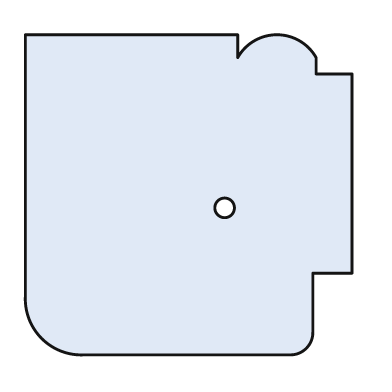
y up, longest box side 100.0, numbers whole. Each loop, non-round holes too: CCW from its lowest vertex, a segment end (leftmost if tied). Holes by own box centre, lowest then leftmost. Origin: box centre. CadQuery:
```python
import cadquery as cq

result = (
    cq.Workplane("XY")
    .moveTo(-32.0, -49.0)
    .lineTo(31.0, -49.0)
    .threePointArc((36.0, -47.0), (38.0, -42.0))
    .lineTo(38.0, -24.0)
    .lineTo(50.0, -24.0)
    .lineTo(50.0, 37.0)
    .lineTo(39.0, 37.0)
    .lineTo(39.0, 42.0)
    .threePointArc((27.0, 49.0), (15.0, 42.0))
    .lineTo(15.0, 49.0)
    .lineTo(-50.0, 49.0)
    .lineTo(-50.0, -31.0)
    .threePointArc((-45.0, -44.0), (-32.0, -49.0))
    .close()
    .moveTo(11.0, -4.0)
    .circle(3.0)
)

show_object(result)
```